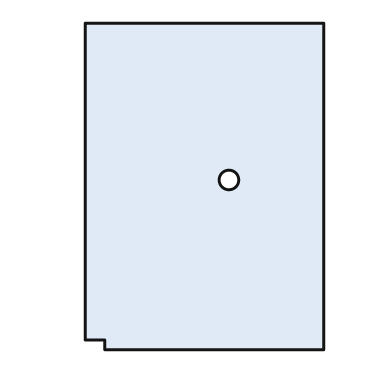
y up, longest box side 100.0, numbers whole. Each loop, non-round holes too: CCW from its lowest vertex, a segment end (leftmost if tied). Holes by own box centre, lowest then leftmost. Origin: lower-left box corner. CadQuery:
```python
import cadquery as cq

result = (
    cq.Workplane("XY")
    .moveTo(6.0, 0.0)
    .lineTo(73.0, 0.0)
    .lineTo(73.0, 100.0)
    .lineTo(0.0, 100.0)
    .lineTo(0.0, 3.0)
    .lineTo(6.0, 3.0)
    .close()
    .moveTo(44.0, 52.0)
    .circle(3.0)
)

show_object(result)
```